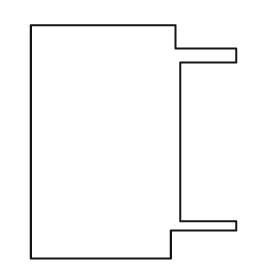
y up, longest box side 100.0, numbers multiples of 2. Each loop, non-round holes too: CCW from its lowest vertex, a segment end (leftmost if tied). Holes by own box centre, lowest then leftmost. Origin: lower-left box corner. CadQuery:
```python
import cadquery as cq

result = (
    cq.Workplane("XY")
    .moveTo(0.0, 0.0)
    .lineTo(60.0, 0.0)
    .lineTo(60.0, 12.0)
    .lineTo(88.0, 12.0)
    .lineTo(88.0, 16.0)
    .lineTo(64.0, 16.0)
    .lineTo(64.0, 84.0)
    .lineTo(88.0, 84.0)
    .lineTo(88.0, 90.0)
    .lineTo(62.0, 90.0)
    .lineTo(62.0, 100.0)
    .lineTo(0.0, 100.0)
    .close()
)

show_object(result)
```